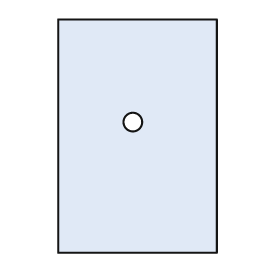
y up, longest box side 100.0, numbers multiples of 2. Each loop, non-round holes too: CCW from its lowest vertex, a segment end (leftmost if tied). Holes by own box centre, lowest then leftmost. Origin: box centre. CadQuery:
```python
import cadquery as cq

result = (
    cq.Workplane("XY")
    .moveTo(-34.0, -50.0)
    .lineTo(34.0, -50.0)
    .lineTo(34.0, 50.0)
    .lineTo(-34.0, 50.0)
    .close()
    .moveTo(-2.0, 6.0)
    .circle(4.0)
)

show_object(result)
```